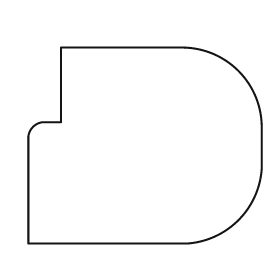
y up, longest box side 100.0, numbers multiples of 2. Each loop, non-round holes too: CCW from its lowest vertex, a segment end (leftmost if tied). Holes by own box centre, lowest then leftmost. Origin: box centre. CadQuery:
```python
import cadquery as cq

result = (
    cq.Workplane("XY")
    .moveTo(-50.0, -42.0)
    .lineTo(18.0, -42.0)
    .threePointArc((40.0, -32.0), (50.0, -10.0))
    .lineTo(50.0, 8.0)
    .threePointArc((40.0, 32.0), (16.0, 42.0))
    .lineTo(-36.0, 42.0)
    .lineTo(-36.0, 10.0)
    .lineTo(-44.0, 10.0)
    .threePointArc((-48.0, 8.0), (-50.0, 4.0))
    .close()
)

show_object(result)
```